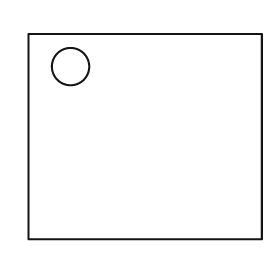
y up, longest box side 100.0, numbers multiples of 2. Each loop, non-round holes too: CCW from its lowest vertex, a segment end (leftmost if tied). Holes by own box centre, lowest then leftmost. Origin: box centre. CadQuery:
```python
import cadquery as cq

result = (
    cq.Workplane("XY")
    .moveTo(-50.0, -44.0)
    .lineTo(50.0, -44.0)
    .lineTo(50.0, 44.0)
    .lineTo(-50.0, 44.0)
    .close()
    .moveTo(-32.0, 30.0)
    .circle(8.0)
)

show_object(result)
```